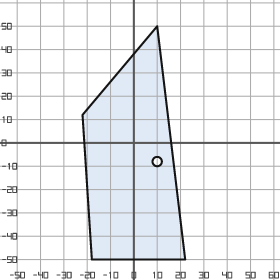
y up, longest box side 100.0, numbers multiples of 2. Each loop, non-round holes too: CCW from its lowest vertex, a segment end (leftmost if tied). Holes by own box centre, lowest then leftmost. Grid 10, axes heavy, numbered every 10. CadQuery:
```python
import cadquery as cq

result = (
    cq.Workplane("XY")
    .moveTo(-18.0, -50.0)
    .lineTo(22.0, -50.0)
    .lineTo(10.0, 50.0)
    .lineTo(-22.0, 12.0)
    .close()
    .moveTo(10.0, -8.0)
    .circle(2.0)
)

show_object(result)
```